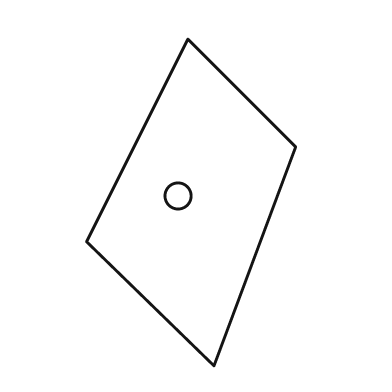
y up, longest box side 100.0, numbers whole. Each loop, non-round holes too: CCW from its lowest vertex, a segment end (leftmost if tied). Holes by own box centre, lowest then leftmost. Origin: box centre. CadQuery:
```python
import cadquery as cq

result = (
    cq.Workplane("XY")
    .moveTo(7.0, -50.0)
    .lineTo(32.0, 17.0)
    .lineTo(-1.0, 50.0)
    .lineTo(-32.0, -12.0)
    .close()
    .moveTo(-4.0, 2.0)
    .circle(4.0)
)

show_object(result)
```